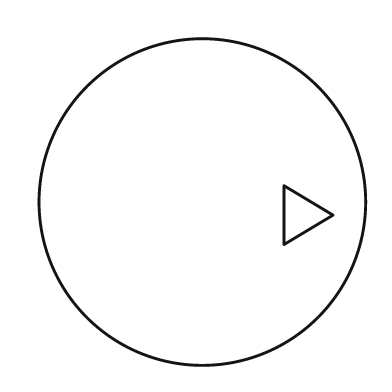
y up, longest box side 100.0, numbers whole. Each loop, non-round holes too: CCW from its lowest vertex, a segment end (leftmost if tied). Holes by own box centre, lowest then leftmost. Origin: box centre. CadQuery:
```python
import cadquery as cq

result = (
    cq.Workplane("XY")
    .moveTo(0.0, 0.0)
    .circle(50.0)
    .moveTo(25.0, -13.0)
    .lineTo(40.0, -4.0)
    .lineTo(25.0, 5.0)
    .close()
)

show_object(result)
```